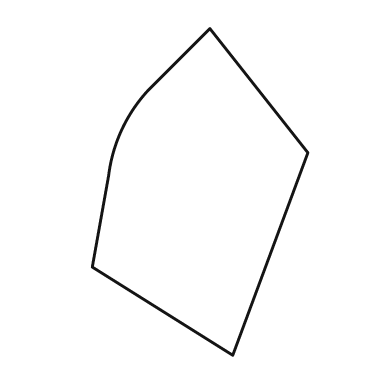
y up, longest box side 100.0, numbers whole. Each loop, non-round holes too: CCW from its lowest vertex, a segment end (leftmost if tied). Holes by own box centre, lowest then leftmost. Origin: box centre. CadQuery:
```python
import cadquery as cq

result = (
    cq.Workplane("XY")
    .moveTo(10.0, -50.0)
    .lineTo(33.0, 12.0)
    .lineTo(3.0, 50.0)
    .lineTo(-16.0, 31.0)
    .threePointArc((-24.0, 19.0), (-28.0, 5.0))
    .lineTo(-33.0, -23.0)
    .close()
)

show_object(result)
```